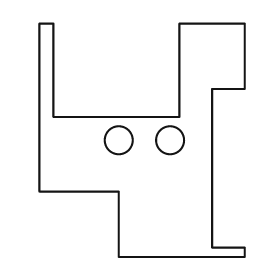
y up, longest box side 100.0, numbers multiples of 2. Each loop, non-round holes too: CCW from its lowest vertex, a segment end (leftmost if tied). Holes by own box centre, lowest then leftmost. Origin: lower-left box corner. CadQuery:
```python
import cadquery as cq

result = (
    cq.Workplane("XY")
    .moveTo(34.0, 0.0)
    .lineTo(88.0, 0.0)
    .lineTo(88.0, 4.0)
    .lineTo(74.0, 4.0)
    .lineTo(74.0, 72.0)
    .lineTo(88.0, 72.0)
    .lineTo(88.0, 100.0)
    .lineTo(60.0, 100.0)
    .lineTo(60.0, 60.0)
    .lineTo(6.0, 60.0)
    .lineTo(6.0, 100.0)
    .lineTo(0.0, 100.0)
    .lineTo(0.0, 28.0)
    .lineTo(34.0, 28.0)
    .close()
    .moveTo(34.0, 50.0)
    .circle(6.0)
    .moveTo(56.0, 50.0)
    .circle(6.0)
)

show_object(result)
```